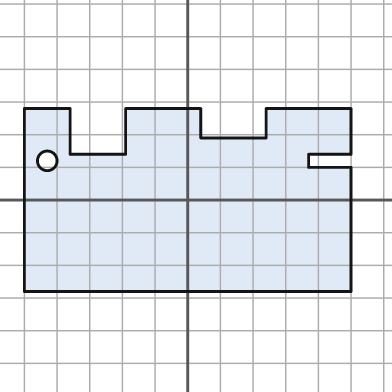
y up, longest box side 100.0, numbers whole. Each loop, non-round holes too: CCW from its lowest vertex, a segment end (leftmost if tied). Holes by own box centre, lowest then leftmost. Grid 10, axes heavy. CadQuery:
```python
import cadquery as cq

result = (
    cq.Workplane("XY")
    .moveTo(-50.0, -28.0)
    .lineTo(50.0, -28.0)
    .lineTo(50.0, 10.0)
    .lineTo(37.0, 10.0)
    .lineTo(37.0, 14.0)
    .lineTo(50.0, 14.0)
    .lineTo(50.0, 28.0)
    .lineTo(24.0, 28.0)
    .lineTo(24.0, 19.0)
    .lineTo(4.0, 19.0)
    .lineTo(4.0, 28.0)
    .lineTo(-19.0, 28.0)
    .lineTo(-19.0, 14.0)
    .lineTo(-36.0, 14.0)
    .lineTo(-36.0, 28.0)
    .lineTo(-50.0, 28.0)
    .close()
    .moveTo(-43.0, 12.0)
    .circle(3.0)
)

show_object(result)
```